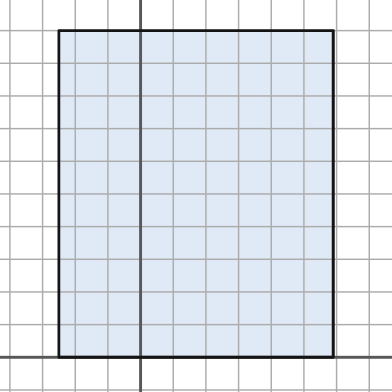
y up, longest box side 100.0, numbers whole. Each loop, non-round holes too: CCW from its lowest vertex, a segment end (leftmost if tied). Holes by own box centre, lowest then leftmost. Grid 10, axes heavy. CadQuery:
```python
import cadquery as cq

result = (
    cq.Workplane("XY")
    .moveTo(-25.0, 0.0)
    .lineTo(59.0, 0.0)
    .lineTo(59.0, 100.0)
    .lineTo(-25.0, 100.0)
    .close()
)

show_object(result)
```